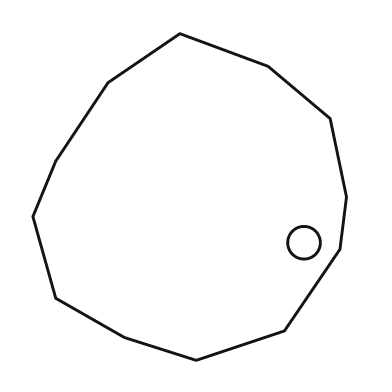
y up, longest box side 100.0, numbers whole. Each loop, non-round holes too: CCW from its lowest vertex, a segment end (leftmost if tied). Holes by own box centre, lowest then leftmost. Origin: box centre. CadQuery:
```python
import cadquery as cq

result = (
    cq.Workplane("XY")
    .moveTo(2.0, -50.0)
    .lineTo(29.0, -41.0)
    .lineTo(46.0, -16.0)
    .lineTo(48.0, 0.0)
    .lineTo(43.0, 24.0)
    .lineTo(24.0, 40.0)
    .lineTo(-3.0, 50.0)
    .lineTo(-25.0, 35.0)
    .lineTo(-41.0, 11.0)
    .lineTo(-48.0, -6.0)
    .lineTo(-41.0, -31.0)
    .lineTo(-20.0, -43.0)
    .close()
    .moveTo(35.0, -14.0)
    .circle(5.0)
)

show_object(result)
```